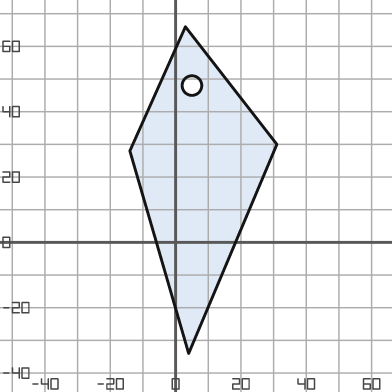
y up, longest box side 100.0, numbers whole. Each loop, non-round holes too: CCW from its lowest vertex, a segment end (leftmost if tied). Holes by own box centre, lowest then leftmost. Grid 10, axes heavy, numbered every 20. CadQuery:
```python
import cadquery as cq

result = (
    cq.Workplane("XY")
    .moveTo(4.0, -34.0)
    .lineTo(31.0, 30.0)
    .lineTo(3.0, 66.0)
    .lineTo(-14.0, 28.0)
    .close()
    .moveTo(5.0, 48.0)
    .circle(3.0)
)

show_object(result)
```